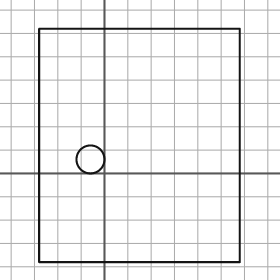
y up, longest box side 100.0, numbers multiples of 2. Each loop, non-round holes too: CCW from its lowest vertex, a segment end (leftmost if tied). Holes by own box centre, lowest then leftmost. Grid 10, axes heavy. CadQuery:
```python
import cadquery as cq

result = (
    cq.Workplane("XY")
    .moveTo(-28.0, -38.0)
    .lineTo(58.0, -38.0)
    .lineTo(58.0, 62.0)
    .lineTo(-28.0, 62.0)
    .close()
    .moveTo(-6.0, 6.0)
    .circle(6.0)
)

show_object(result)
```